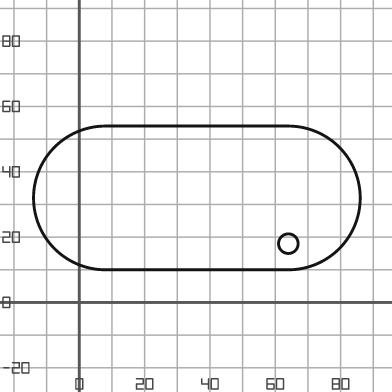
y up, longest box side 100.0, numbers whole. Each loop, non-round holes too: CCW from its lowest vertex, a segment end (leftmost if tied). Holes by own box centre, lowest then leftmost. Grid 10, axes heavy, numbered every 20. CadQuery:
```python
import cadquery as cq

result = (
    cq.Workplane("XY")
    .moveTo(8.0, 10.0)
    .lineTo(64.0, 10.0)
    .threePointArc((86.0, 32.0), (64.0, 54.0))
    .lineTo(8.0, 54.0)
    .threePointArc((-14.0, 32.0), (8.0, 10.0))
    .close()
    .moveTo(64.0, 18.0)
    .circle(3.0)
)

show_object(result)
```